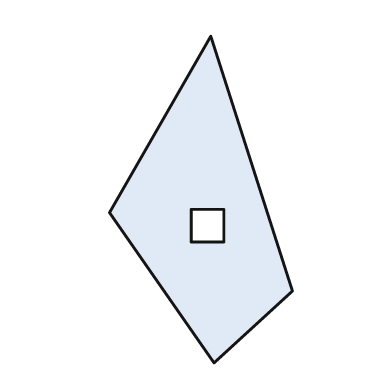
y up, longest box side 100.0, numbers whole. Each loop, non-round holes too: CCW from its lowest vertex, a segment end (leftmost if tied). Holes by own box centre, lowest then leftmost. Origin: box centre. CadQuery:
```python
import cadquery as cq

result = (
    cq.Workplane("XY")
    .moveTo(4.0, -50.0)
    .lineTo(28.0, -28.0)
    .lineTo(3.0, 50.0)
    .lineTo(-28.0, -4.0)
    .close()
    .moveTo(-3.0, -13.0)
    .lineTo(7.0, -13.0)
    .lineTo(7.0, -3.0)
    .lineTo(-3.0, -3.0)
    .close()
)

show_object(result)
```